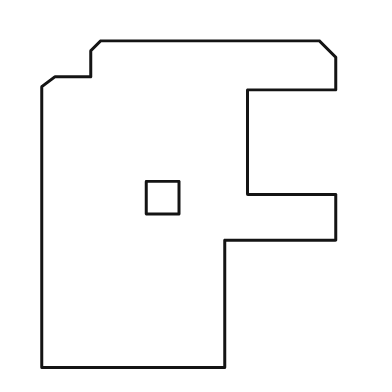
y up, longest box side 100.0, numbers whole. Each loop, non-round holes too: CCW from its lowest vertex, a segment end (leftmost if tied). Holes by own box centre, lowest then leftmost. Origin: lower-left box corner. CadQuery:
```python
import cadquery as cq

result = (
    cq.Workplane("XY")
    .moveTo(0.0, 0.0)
    .lineTo(56.0, 0.0)
    .lineTo(56.0, 39.0)
    .lineTo(90.0, 39.0)
    .lineTo(90.0, 53.0)
    .lineTo(63.0, 53.0)
    .lineTo(63.0, 85.0)
    .lineTo(90.0, 85.0)
    .lineTo(90.0, 95.0)
    .lineTo(85.0, 100.0)
    .lineTo(18.0, 100.0)
    .lineTo(15.0, 97.0)
    .lineTo(15.0, 89.0)
    .lineTo(4.0, 89.0)
    .lineTo(0.0, 86.0)
    .close()
    .moveTo(32.0, 47.0)
    .lineTo(42.0, 47.0)
    .lineTo(42.0, 57.0)
    .lineTo(32.0, 57.0)
    .close()
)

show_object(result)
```